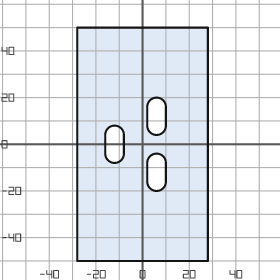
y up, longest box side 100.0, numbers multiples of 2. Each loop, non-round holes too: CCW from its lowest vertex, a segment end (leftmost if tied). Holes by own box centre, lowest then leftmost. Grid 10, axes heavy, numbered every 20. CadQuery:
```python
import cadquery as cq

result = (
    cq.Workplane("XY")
    .moveTo(-28.0, -50.0)
    .lineTo(28.0, -50.0)
    .lineTo(28.0, 50.0)
    .lineTo(-28.0, 50.0)
    .close()
    .moveTo(2.0, -16.0)
    .threePointArc((6.0, -20.0), (10.0, -16.0))
    .lineTo(10.0, -8.0)
    .threePointArc((6.0, -4.0), (2.0, -8.0))
    .close()
    .moveTo(-16.0, -4.0)
    .threePointArc((-12.0, -8.0), (-8.0, -4.0))
    .lineTo(-8.0, 4.0)
    .threePointArc((-12.0, 8.0), (-16.0, 4.0))
    .close()
    .moveTo(2.0, 8.0)
    .threePointArc((6.0, 4.0), (10.0, 8.0))
    .lineTo(10.0, 16.0)
    .threePointArc((6.0, 20.0), (2.0, 16.0))
    .close()
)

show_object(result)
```